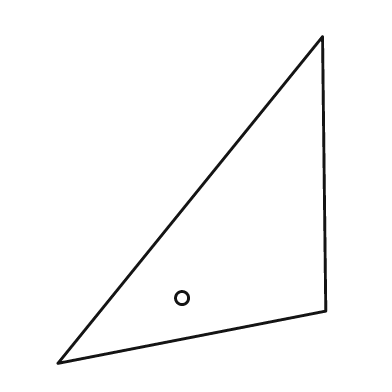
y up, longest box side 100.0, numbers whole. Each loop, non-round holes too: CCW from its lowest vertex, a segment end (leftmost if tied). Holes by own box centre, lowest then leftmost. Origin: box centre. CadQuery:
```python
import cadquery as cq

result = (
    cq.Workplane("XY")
    .moveTo(-41.0, -50.0)
    .lineTo(41.0, -34.0)
    .lineTo(40.0, 50.0)
    .close()
    .moveTo(-3.0, -30.0)
    .circle(2.0)
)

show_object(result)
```